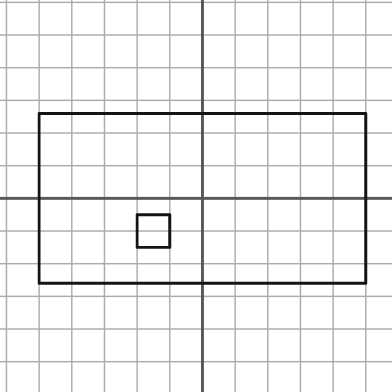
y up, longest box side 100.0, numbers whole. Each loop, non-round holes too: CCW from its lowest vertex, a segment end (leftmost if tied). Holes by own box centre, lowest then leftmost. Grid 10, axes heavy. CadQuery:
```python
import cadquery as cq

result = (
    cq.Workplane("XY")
    .moveTo(-50.0, -26.0)
    .lineTo(50.0, -26.0)
    .lineTo(50.0, 26.0)
    .lineTo(-50.0, 26.0)
    .close()
    .moveTo(-20.0, -15.0)
    .lineTo(-10.0, -15.0)
    .lineTo(-10.0, -5.0)
    .lineTo(-20.0, -5.0)
    .close()
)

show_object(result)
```